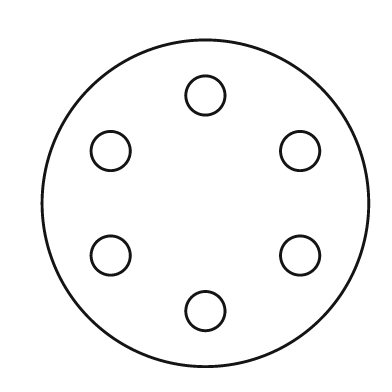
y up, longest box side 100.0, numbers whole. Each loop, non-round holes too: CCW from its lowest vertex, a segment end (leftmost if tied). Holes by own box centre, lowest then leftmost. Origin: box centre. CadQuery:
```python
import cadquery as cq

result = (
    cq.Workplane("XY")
    .moveTo(0.0, 0.0)
    .circle(50.0)
    .moveTo(0.0, -33.0)
    .circle(6.0)
    .moveTo(-29.0, -16.0)
    .circle(6.0)
    .moveTo(29.0, -16.0)
    .circle(6.0)
    .moveTo(-29.0, 16.0)
    .circle(6.0)
    .moveTo(29.0, 16.0)
    .circle(6.0)
    .moveTo(0.0, 33.0)
    .circle(6.0)
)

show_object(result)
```